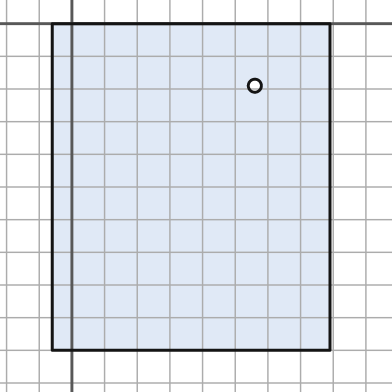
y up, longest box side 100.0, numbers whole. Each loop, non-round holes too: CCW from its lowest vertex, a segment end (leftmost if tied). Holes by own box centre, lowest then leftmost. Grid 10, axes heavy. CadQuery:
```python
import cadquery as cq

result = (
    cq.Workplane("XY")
    .moveTo(-6.0, -100.0)
    .lineTo(79.0, -100.0)
    .lineTo(79.0, 0.0)
    .lineTo(-6.0, 0.0)
    .close()
    .moveTo(56.0, -19.0)
    .circle(2.0)
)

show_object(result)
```